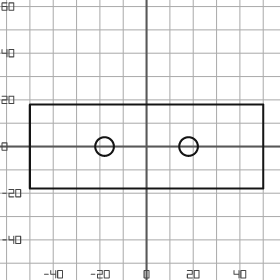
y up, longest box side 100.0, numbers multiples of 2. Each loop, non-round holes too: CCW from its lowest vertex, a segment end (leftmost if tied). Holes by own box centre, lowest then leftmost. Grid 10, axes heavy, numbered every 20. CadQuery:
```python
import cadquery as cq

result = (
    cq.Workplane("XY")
    .moveTo(-50.0, -18.0)
    .lineTo(50.0, -18.0)
    .lineTo(50.0, 18.0)
    .lineTo(-50.0, 18.0)
    .close()
    .moveTo(-18.0, 0.0)
    .circle(4.0)
    .moveTo(18.0, 0.0)
    .circle(4.0)
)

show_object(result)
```